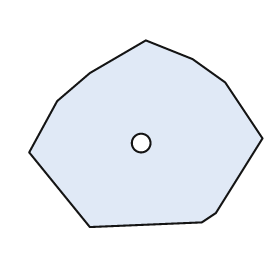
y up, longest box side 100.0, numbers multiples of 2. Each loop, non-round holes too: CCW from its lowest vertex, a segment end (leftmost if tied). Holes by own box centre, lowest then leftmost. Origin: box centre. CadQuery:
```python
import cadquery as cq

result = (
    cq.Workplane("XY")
    .moveTo(-24.0, -40.0)
    .lineTo(24.0, -38.0)
    .lineTo(30.0, -34.0)
    .lineTo(50.0, -2.0)
    .lineTo(34.0, 22.0)
    .lineTo(20.0, 32.0)
    .lineTo(0.0, 40.0)
    .lineTo(-24.0, 26.0)
    .lineTo(-38.0, 14.0)
    .lineTo(-50.0, -8.0)
    .close()
    .moveTo(-2.0, -4.0)
    .circle(4.0)
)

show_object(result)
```